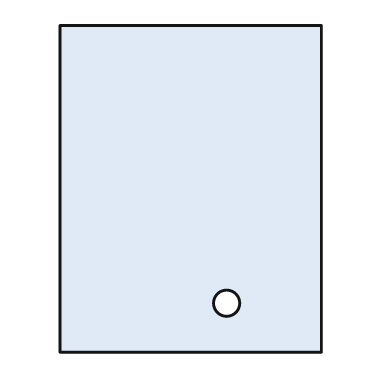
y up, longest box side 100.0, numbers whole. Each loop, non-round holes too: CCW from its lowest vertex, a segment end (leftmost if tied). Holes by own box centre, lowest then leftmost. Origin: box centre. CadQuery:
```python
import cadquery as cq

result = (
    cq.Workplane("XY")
    .moveTo(-40.0, -50.0)
    .lineTo(40.0, -50.0)
    .lineTo(40.0, 50.0)
    .lineTo(-40.0, 50.0)
    .close()
    .moveTo(11.0, -35.0)
    .circle(4.0)
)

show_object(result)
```